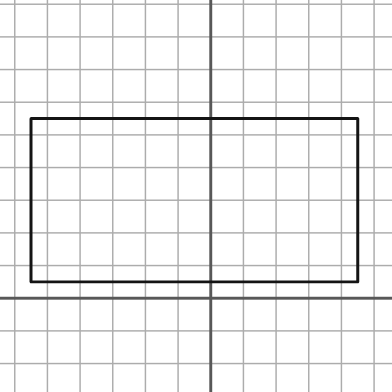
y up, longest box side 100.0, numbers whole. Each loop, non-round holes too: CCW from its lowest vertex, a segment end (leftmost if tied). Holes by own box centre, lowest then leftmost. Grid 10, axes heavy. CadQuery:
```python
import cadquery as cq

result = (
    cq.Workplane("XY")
    .moveTo(-55.0, 5.0)
    .lineTo(45.0, 5.0)
    .lineTo(45.0, 55.0)
    .lineTo(-55.0, 55.0)
    .close()
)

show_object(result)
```